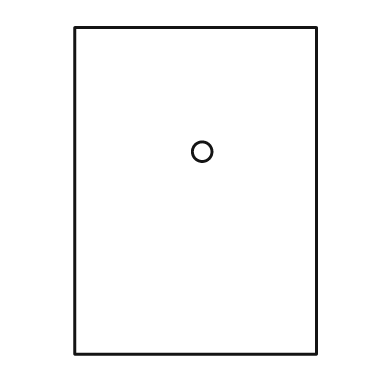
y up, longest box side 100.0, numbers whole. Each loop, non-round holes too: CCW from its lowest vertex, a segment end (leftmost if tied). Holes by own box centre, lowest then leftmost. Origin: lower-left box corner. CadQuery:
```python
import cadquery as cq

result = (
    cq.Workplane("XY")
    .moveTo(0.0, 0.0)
    .lineTo(74.0, 0.0)
    .lineTo(74.0, 100.0)
    .lineTo(0.0, 100.0)
    .close()
    .moveTo(39.0, 62.0)
    .circle(3.0)
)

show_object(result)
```